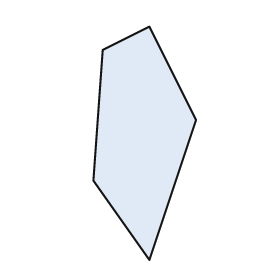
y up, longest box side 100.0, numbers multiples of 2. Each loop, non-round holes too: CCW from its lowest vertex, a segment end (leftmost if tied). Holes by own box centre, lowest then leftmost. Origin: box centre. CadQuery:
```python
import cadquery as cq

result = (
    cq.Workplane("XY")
    .moveTo(2.0, -50.0)
    .lineTo(22.0, 10.0)
    .lineTo(2.0, 50.0)
    .lineTo(-18.0, 40.0)
    .lineTo(-22.0, -16.0)
    .close()
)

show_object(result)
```